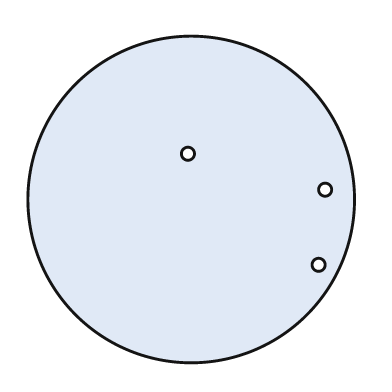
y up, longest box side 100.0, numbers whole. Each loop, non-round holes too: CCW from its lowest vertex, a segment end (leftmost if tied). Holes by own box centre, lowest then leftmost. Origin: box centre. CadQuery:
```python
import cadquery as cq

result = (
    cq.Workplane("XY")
    .moveTo(0.0, 0.0)
    .circle(50.0)
    .moveTo(39.0, -20.0)
    .circle(2.0)
    .moveTo(41.0, 3.0)
    .circle(2.0)
    .moveTo(-1.0, 14.0)
    .circle(2.0)
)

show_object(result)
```